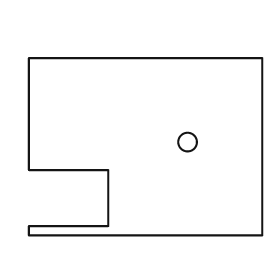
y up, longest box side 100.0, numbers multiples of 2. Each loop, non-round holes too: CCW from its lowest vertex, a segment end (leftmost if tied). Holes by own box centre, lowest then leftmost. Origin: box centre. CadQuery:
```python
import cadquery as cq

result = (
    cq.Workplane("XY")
    .moveTo(-50.0, -38.0)
    .lineTo(50.0, -38.0)
    .lineTo(50.0, 38.0)
    .lineTo(-50.0, 38.0)
    .lineTo(-50.0, -10.0)
    .lineTo(-16.0, -10.0)
    .lineTo(-16.0, -34.0)
    .lineTo(-50.0, -34.0)
    .close()
    .moveTo(18.0, 2.0)
    .circle(4.0)
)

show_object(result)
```